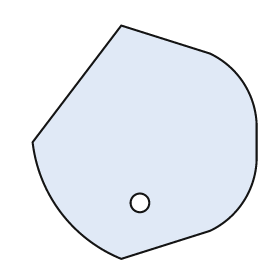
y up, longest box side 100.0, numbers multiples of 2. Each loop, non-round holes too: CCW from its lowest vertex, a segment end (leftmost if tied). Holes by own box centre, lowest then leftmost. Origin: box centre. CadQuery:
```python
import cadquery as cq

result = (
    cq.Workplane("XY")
    .moveTo(-10.0, -50.0)
    .lineTo(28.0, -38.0)
    .threePointArc((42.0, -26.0), (48.0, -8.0))
    .lineTo(48.0, 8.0)
    .threePointArc((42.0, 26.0), (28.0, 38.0))
    .lineTo(-10.0, 50.0)
    .lineTo(-48.0, 0.0)
    .threePointArc((-36.0, -30.0), (-10.0, -50.0))
    .close()
    .moveTo(-2.0, -26.0)
    .circle(4.0)
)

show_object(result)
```